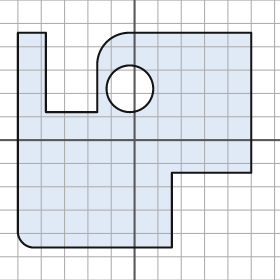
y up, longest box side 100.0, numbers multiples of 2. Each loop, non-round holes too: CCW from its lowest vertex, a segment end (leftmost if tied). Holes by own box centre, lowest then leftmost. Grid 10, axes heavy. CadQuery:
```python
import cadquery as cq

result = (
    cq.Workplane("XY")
    .moveTo(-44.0, -46.0)
    .lineTo(16.0, -46.0)
    .lineTo(16.0, -14.0)
    .lineTo(50.0, -14.0)
    .lineTo(50.0, 46.0)
    .lineTo(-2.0, 46.0)
    .threePointArc((-12.0, 42.0), (-16.0, 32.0))
    .lineTo(-16.0, 12.0)
    .lineTo(-38.0, 12.0)
    .lineTo(-38.0, 46.0)
    .lineTo(-50.0, 46.0)
    .lineTo(-50.0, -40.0)
    .threePointArc((-48.0, -44.0), (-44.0, -46.0))
    .close()
    .moveTo(-2.0, 22.0)
    .circle(10.0)
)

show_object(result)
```